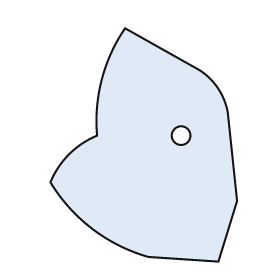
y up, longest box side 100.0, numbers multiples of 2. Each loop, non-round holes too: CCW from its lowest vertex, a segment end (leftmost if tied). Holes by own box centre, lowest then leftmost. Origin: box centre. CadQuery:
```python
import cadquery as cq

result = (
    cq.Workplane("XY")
    .moveTo(32.0, -50.0)
    .lineTo(40.0, -24.0)
    .lineTo(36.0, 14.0)
    .threePointArc((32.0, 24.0), (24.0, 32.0))
    .lineTo(-8.0, 50.0)
    .threePointArc((-18.0, 28.0), (-20.0, 4.0))
    .threePointArc((-32.0, -4.0), (-40.0, -16.0))
    .threePointArc((-22.0, -36.0), (2.0, -48.0))
    .close()
    .moveTo(16.0, 4.0)
    .circle(4.0)
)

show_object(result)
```